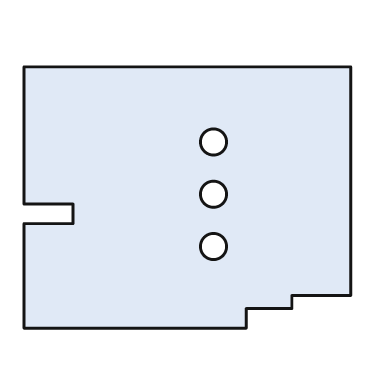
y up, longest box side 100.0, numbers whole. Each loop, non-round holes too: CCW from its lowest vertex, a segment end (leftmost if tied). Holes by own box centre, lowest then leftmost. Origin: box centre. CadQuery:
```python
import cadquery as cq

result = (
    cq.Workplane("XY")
    .moveTo(-50.0, -40.0)
    .lineTo(18.0, -40.0)
    .lineTo(18.0, -34.0)
    .lineTo(32.0, -34.0)
    .lineTo(32.0, -30.0)
    .lineTo(50.0, -30.0)
    .lineTo(50.0, 40.0)
    .lineTo(-50.0, 40.0)
    .lineTo(-50.0, -2.0)
    .lineTo(-35.0, -2.0)
    .lineTo(-35.0, -8.0)
    .lineTo(-50.0, -8.0)
    .close()
    .moveTo(8.0, -15.0)
    .circle(4.0)
    .moveTo(8.0, 1.0)
    .circle(4.0)
    .moveTo(8.0, 17.0)
    .circle(4.0)
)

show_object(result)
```